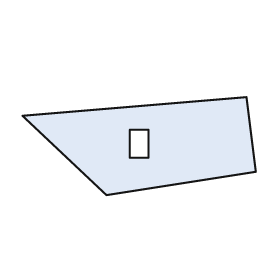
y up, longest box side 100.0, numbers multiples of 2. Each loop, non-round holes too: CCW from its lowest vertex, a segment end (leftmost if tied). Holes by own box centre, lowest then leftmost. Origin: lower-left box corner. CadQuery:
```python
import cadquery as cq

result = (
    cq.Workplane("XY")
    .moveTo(36.0, 0.0)
    .lineTo(100.0, 10.0)
    .lineTo(96.0, 42.0)
    .lineTo(0.0, 34.0)
    .close()
    .moveTo(46.0, 16.0)
    .lineTo(54.0, 16.0)
    .lineTo(54.0, 28.0)
    .lineTo(46.0, 28.0)
    .close()
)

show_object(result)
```